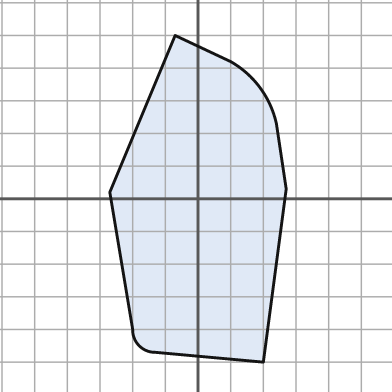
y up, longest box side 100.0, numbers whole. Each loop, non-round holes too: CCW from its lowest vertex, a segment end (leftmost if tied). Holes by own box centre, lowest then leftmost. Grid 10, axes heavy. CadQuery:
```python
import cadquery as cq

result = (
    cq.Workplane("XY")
    .moveTo(20.0, -50.0)
    .lineTo(27.0, 3.0)
    .lineTo(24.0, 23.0)
    .threePointArc((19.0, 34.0), (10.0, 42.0))
    .lineTo(-7.0, 50.0)
    .lineTo(-27.0, 2.0)
    .lineTo(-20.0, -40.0)
    .threePointArc((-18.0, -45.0), (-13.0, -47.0))
    .close()
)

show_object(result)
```